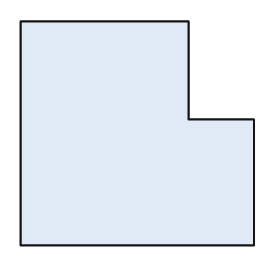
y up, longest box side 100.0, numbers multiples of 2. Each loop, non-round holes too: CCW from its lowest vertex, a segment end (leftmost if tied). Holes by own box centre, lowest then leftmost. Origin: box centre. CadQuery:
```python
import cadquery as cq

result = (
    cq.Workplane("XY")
    .moveTo(-50.0, -48.0)
    .lineTo(50.0, -48.0)
    .lineTo(50.0, 6.0)
    .lineTo(22.0, 6.0)
    .lineTo(22.0, 48.0)
    .lineTo(-50.0, 48.0)
    .close()
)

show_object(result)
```